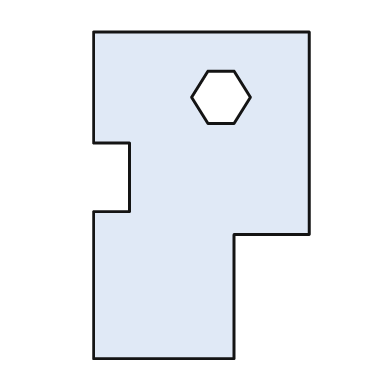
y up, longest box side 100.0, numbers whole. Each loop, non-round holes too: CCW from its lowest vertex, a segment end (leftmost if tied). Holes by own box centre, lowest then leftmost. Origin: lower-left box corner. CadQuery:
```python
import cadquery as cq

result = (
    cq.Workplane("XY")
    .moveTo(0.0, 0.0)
    .lineTo(43.0, 0.0)
    .lineTo(43.0, 38.0)
    .lineTo(66.0, 38.0)
    .lineTo(66.0, 100.0)
    .lineTo(0.0, 100.0)
    .lineTo(0.0, 66.0)
    .lineTo(11.0, 66.0)
    .lineTo(11.0, 45.0)
    .lineTo(0.0, 45.0)
    .close()
    .moveTo(35.0, 72.0)
    .lineTo(43.0, 72.0)
    .lineTo(48.0, 80.0)
    .lineTo(43.0, 88.0)
    .lineTo(35.0, 88.0)
    .lineTo(30.0, 80.0)
    .close()
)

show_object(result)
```